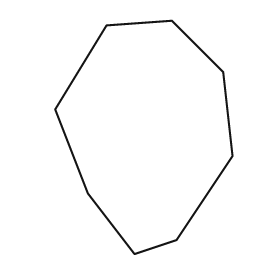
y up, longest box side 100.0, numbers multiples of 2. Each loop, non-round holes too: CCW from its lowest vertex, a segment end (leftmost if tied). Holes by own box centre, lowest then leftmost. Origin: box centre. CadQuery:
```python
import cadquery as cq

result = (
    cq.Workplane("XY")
    .moveTo(-4.0, -50.0)
    .lineTo(14.0, -44.0)
    .lineTo(38.0, -8.0)
    .lineTo(34.0, 28.0)
    .lineTo(12.0, 50.0)
    .lineTo(-16.0, 48.0)
    .lineTo(-38.0, 12.0)
    .lineTo(-24.0, -24.0)
    .close()
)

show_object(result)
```